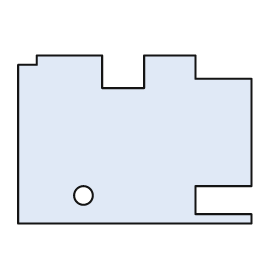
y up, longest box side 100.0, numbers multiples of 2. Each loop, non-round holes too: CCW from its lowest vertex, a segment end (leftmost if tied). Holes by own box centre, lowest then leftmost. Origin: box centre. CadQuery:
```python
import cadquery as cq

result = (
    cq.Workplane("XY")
    .moveTo(-50.0, -36.0)
    .lineTo(50.0, -36.0)
    .lineTo(50.0, -32.0)
    .lineTo(26.0, -32.0)
    .lineTo(26.0, -20.0)
    .lineTo(50.0, -20.0)
    .lineTo(50.0, 26.0)
    .lineTo(26.0, 26.0)
    .lineTo(26.0, 36.0)
    .lineTo(4.0, 36.0)
    .lineTo(4.0, 22.0)
    .lineTo(-14.0, 22.0)
    .lineTo(-14.0, 36.0)
    .lineTo(-42.0, 36.0)
    .lineTo(-42.0, 32.0)
    .lineTo(-50.0, 32.0)
    .close()
    .moveTo(-22.0, -24.0)
    .circle(4.0)
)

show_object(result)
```